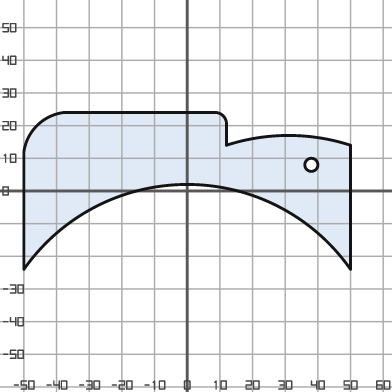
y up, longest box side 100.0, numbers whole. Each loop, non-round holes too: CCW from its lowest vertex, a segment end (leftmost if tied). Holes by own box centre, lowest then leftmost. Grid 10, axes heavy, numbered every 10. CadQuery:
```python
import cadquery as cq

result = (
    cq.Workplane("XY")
    .moveTo(-50.0, -24.0)
    .threePointArc((0.0, 2.0), (50.0, -24.0))
    .lineTo(50.0, 14.0)
    .threePointArc((31.0, 17.0), (12.0, 14.0))
    .lineTo(12.0, 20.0)
    .threePointArc((11.0, 23.0), (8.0, 24.0))
    .lineTo(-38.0, 24.0)
    .threePointArc((-46.0, 20.0), (-50.0, 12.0))
    .close()
    .moveTo(38.0, 8.0)
    .circle(2.0)
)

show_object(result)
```